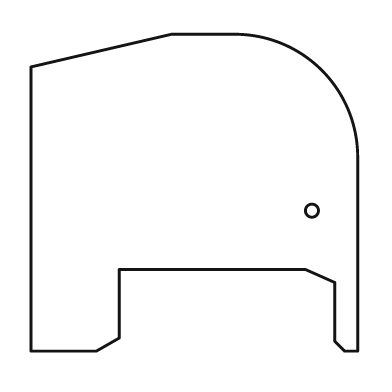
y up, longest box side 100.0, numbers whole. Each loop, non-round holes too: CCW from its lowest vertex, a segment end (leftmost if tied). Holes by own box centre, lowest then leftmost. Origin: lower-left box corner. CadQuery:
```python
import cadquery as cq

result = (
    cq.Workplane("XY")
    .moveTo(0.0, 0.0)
    .lineTo(20.0, 0.0)
    .lineTo(27.0, 4.0)
    .lineTo(27.0, 25.0)
    .lineTo(84.0, 25.0)
    .lineTo(93.0, 21.0)
    .lineTo(93.0, 3.0)
    .lineTo(96.0, 0.0)
    .lineTo(100.0, 0.0)
    .lineTo(100.0, 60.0)
    .threePointArc((89.0, 86.0), (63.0, 97.0))
    .lineTo(43.0, 97.0)
    .lineTo(0.0, 87.0)
    .close()
    .moveTo(86.0, 43.0)
    .circle(2.0)
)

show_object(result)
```